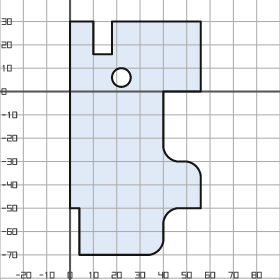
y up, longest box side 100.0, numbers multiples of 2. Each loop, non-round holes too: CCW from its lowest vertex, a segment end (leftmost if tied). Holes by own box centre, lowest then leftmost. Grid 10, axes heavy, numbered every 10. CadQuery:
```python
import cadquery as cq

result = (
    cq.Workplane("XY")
    .moveTo(4.0, -70.0)
    .lineTo(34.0, -70.0)
    .threePointArc((38.0, -68.0), (40.0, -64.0))
    .lineTo(40.0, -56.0)
    .threePointArc((42.0, -52.0), (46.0, -50.0))
    .lineTo(56.0, -50.0)
    .lineTo(56.0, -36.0)
    .threePointArc((54.0, -32.0), (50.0, -30.0))
    .lineTo(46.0, -30.0)
    .threePointArc((42.0, -28.0), (40.0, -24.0))
    .lineTo(40.0, 0.0)
    .lineTo(56.0, 0.0)
    .lineTo(56.0, 30.0)
    .lineTo(18.0, 30.0)
    .lineTo(18.0, 16.0)
    .lineTo(10.0, 16.0)
    .lineTo(10.0, 30.0)
    .lineTo(0.0, 30.0)
    .lineTo(0.0, -50.0)
    .lineTo(4.0, -50.0)
    .close()
    .moveTo(22.0, 6.0)
    .circle(4.0)
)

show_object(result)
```